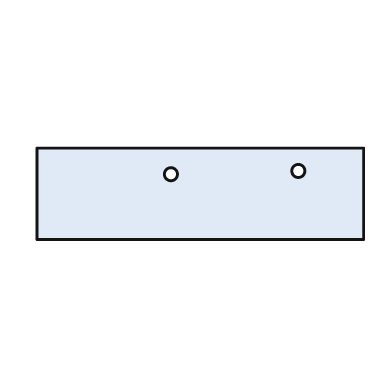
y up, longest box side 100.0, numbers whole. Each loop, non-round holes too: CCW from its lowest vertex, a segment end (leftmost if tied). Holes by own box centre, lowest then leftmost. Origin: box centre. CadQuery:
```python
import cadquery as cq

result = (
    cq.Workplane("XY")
    .moveTo(-50.0, -14.0)
    .lineTo(50.0, -14.0)
    .lineTo(50.0, 14.0)
    .lineTo(-50.0, 14.0)
    .close()
    .moveTo(-9.0, 6.0)
    .circle(2.0)
    .moveTo(30.0, 7.0)
    .circle(2.0)
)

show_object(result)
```